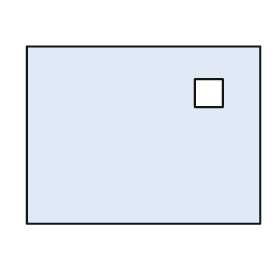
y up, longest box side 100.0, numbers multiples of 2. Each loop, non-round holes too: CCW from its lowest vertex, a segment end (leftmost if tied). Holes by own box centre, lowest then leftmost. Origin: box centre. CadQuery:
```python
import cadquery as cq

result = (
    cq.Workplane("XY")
    .moveTo(-50.0, -38.0)
    .lineTo(50.0, -38.0)
    .lineTo(50.0, 38.0)
    .lineTo(-50.0, 38.0)
    .close()
    .moveTo(22.0, 12.0)
    .lineTo(34.0, 12.0)
    .lineTo(34.0, 24.0)
    .lineTo(22.0, 24.0)
    .close()
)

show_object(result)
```